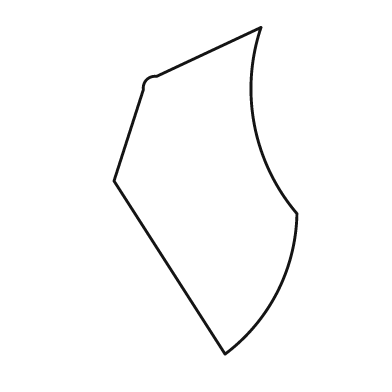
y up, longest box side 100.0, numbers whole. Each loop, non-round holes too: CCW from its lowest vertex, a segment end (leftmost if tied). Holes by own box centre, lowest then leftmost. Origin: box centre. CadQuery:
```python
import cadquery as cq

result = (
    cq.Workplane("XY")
    .moveTo(6.0, -50.0)
    .threePointArc((22.0, -31.0), (28.0, -7.0))
    .threePointArc((15.0, 20.0), (17.0, 50.0))
    .lineTo(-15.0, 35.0)
    .threePointArc((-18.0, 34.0), (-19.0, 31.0))
    .lineTo(-28.0, 3.0)
    .close()
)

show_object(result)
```